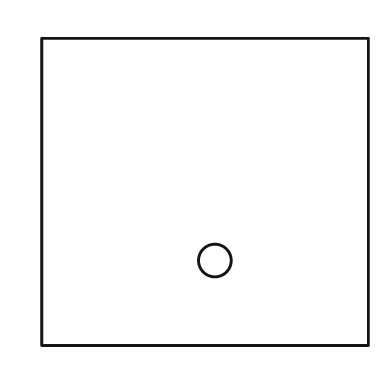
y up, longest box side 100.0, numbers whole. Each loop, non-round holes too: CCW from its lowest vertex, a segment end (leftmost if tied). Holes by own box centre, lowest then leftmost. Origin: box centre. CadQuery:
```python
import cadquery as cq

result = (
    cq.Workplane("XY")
    .moveTo(-50.0, -47.0)
    .lineTo(50.0, -47.0)
    .lineTo(50.0, 47.0)
    .lineTo(-50.0, 47.0)
    .close()
    .moveTo(3.0, -21.0)
    .circle(5.0)
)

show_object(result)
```